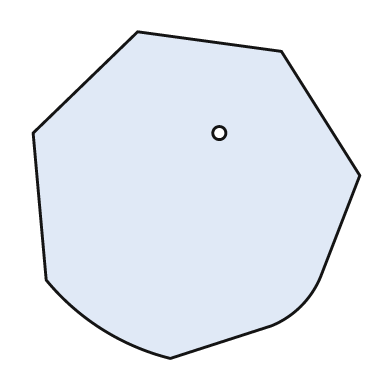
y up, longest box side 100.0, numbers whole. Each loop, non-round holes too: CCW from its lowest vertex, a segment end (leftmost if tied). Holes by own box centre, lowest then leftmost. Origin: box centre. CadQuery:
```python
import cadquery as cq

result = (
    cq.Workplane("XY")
    .moveTo(-8.0, -50.0)
    .lineTo(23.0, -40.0)
    .threePointArc((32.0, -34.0), (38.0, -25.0))
    .lineTo(50.0, 6.0)
    .lineTo(26.0, 44.0)
    .lineTo(-18.0, 50.0)
    .lineTo(-50.0, 19.0)
    .lineTo(-46.0, -26.0)
    .threePointArc((-29.0, -41.0), (-8.0, -50.0))
    .close()
    .moveTo(7.0, 19.0)
    .circle(2.0)
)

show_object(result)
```